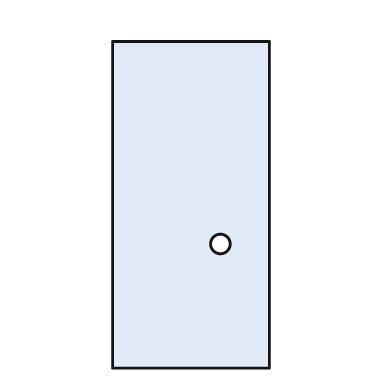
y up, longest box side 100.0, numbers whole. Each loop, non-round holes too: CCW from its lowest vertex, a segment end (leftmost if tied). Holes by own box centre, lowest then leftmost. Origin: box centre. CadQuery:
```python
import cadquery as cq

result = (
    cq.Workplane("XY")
    .moveTo(-24.0, -50.0)
    .lineTo(24.0, -50.0)
    .lineTo(24.0, 50.0)
    .lineTo(-24.0, 50.0)
    .close()
    .moveTo(9.0, -12.0)
    .circle(3.0)
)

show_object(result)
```